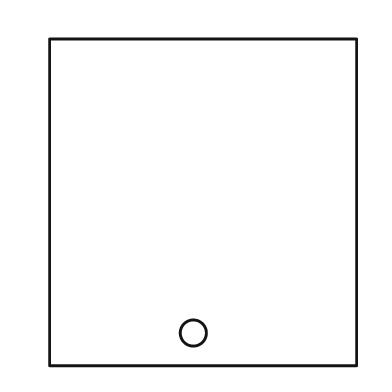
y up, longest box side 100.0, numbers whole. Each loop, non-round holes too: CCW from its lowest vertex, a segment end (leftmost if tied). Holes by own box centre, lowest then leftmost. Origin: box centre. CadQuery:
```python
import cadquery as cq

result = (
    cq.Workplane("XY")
    .moveTo(-47.0, -50.0)
    .lineTo(47.0, -50.0)
    .lineTo(47.0, 50.0)
    .lineTo(-47.0, 50.0)
    .close()
    .moveTo(-3.0, -40.0)
    .circle(4.0)
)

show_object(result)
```